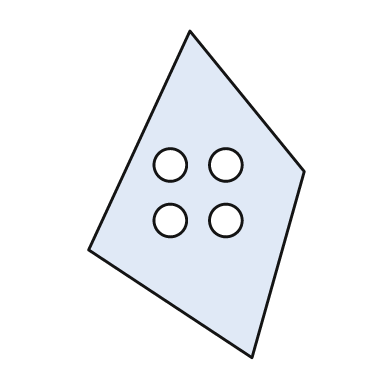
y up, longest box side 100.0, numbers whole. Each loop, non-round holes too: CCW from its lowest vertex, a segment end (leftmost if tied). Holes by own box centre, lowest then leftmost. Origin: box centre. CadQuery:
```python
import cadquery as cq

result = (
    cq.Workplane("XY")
    .moveTo(17.0, -50.0)
    .lineTo(33.0, 7.0)
    .lineTo(-2.0, 50.0)
    .lineTo(-33.0, -17.0)
    .close()
    .moveTo(-8.0, -8.0)
    .circle(5.0)
    .moveTo(9.0, -8.0)
    .circle(5.0)
    .moveTo(-8.0, 9.0)
    .circle(5.0)
    .moveTo(9.0, 9.0)
    .circle(5.0)
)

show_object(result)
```